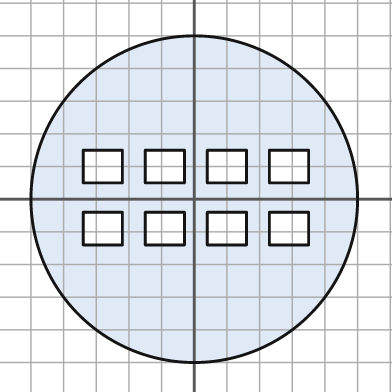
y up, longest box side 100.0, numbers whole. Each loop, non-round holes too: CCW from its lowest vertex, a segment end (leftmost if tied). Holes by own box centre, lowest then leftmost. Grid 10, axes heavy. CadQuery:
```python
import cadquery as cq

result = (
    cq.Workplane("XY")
    .moveTo(0.0, 0.0)
    .circle(50.0)
    .moveTo(-34.0, -14.0)
    .lineTo(-22.0, -14.0)
    .lineTo(-22.0, -4.0)
    .lineTo(-34.0, -4.0)
    .close()
    .moveTo(-15.0, -14.0)
    .lineTo(-3.0, -14.0)
    .lineTo(-3.0, -4.0)
    .lineTo(-15.0, -4.0)
    .close()
    .moveTo(4.0, -14.0)
    .lineTo(16.0, -14.0)
    .lineTo(16.0, -4.0)
    .lineTo(4.0, -4.0)
    .close()
    .moveTo(23.0, -14.0)
    .lineTo(35.0, -14.0)
    .lineTo(35.0, -4.0)
    .lineTo(23.0, -4.0)
    .close()
    .moveTo(-34.0, 5.0)
    .lineTo(-22.0, 5.0)
    .lineTo(-22.0, 15.0)
    .lineTo(-34.0, 15.0)
    .close()
    .moveTo(-15.0, 5.0)
    .lineTo(-3.0, 5.0)
    .lineTo(-3.0, 15.0)
    .lineTo(-15.0, 15.0)
    .close()
    .moveTo(4.0, 5.0)
    .lineTo(16.0, 5.0)
    .lineTo(16.0, 15.0)
    .lineTo(4.0, 15.0)
    .close()
    .moveTo(23.0, 5.0)
    .lineTo(35.0, 5.0)
    .lineTo(35.0, 15.0)
    .lineTo(23.0, 15.0)
    .close()
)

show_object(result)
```